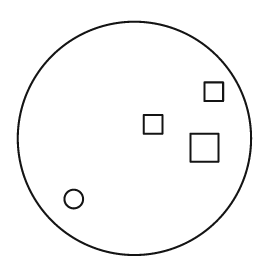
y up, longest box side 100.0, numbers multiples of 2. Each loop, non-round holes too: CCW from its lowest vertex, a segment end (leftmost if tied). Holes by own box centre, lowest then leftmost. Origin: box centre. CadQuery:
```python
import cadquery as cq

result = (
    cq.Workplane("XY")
    .moveTo(0.0, 0.0)
    .circle(50.0)
    .moveTo(-26.0, -26.0)
    .circle(4.0)
    .moveTo(24.0, -10.0)
    .lineTo(36.0, -10.0)
    .lineTo(36.0, 2.0)
    .lineTo(24.0, 2.0)
    .close()
    .moveTo(4.0, 2.0)
    .lineTo(12.0, 2.0)
    .lineTo(12.0, 10.0)
    .lineTo(4.0, 10.0)
    .close()
    .moveTo(30.0, 16.0)
    .lineTo(38.0, 16.0)
    .lineTo(38.0, 24.0)
    .lineTo(30.0, 24.0)
    .close()
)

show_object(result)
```